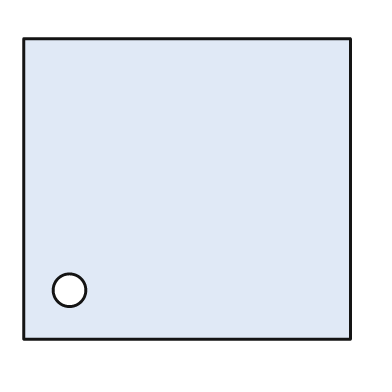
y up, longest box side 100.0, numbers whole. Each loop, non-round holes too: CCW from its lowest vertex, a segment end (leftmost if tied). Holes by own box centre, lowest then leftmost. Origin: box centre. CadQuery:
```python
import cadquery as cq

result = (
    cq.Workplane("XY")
    .moveTo(-50.0, -46.0)
    .lineTo(50.0, -46.0)
    .lineTo(50.0, 46.0)
    .lineTo(-50.0, 46.0)
    .close()
    .moveTo(-36.0, -31.0)
    .circle(5.0)
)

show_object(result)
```